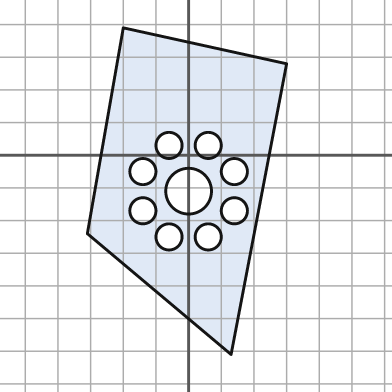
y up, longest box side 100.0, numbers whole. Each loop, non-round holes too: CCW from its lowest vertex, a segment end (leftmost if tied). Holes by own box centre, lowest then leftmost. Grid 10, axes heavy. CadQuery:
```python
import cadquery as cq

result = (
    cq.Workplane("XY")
    .moveTo(13.0, -61.0)
    .lineTo(30.0, 28.0)
    .lineTo(-20.0, 39.0)
    .lineTo(-31.0, -24.0)
    .close()
    .moveTo(-6.0, -25.0)
    .circle(4.0)
    .moveTo(6.0, -25.0)
    .circle(4.0)
    .moveTo(-14.0, -17.0)
    .circle(4.0)
    .moveTo(14.0, -17.0)
    .circle(4.0)
    .moveTo(0.0, -11.0)
    .circle(7.0)
    .moveTo(-14.0, -5.0)
    .circle(4.0)
    .moveTo(14.0, -5.0)
    .circle(4.0)
    .moveTo(-6.0, 3.0)
    .circle(4.0)
    .moveTo(6.0, 3.0)
    .circle(4.0)
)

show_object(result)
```